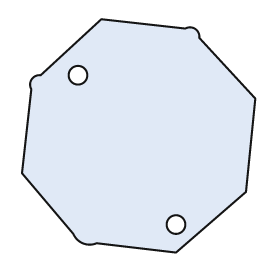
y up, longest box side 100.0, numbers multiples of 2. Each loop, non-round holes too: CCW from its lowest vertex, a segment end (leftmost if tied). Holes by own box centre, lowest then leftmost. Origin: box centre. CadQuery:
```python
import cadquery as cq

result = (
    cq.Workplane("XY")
    .moveTo(16.0, -50.0)
    .lineTo(46.0, -24.0)
    .lineTo(50.0, 16.0)
    .lineTo(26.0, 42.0)
    .threePointArc((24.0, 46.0), (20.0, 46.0))
    .lineTo(-16.0, 50.0)
    .lineTo(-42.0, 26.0)
    .threePointArc((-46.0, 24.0), (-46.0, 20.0))
    .lineTo(-50.0, -16.0)
    .lineTo(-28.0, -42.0)
    .threePointArc((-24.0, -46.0), (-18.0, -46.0))
    .close()
    .moveTo(16.0, -38.0)
    .circle(4.0)
    .moveTo(-26.0, 26.0)
    .circle(4.0)
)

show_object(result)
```